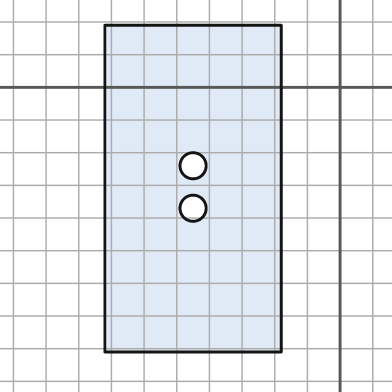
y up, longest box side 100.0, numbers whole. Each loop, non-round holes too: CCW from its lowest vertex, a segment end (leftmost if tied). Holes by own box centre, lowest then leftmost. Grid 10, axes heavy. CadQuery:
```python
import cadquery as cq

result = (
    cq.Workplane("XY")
    .moveTo(-72.0, -81.0)
    .lineTo(-18.0, -81.0)
    .lineTo(-18.0, 19.0)
    .lineTo(-72.0, 19.0)
    .close()
    .moveTo(-45.0, -37.0)
    .circle(4.0)
    .moveTo(-45.0, -24.0)
    .circle(4.0)
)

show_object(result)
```